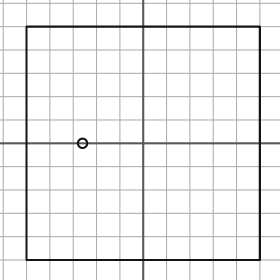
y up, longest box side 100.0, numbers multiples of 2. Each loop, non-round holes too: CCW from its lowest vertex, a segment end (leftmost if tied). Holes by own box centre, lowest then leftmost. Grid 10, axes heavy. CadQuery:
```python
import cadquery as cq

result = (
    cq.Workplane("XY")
    .moveTo(-50.0, -50.0)
    .lineTo(50.0, -50.0)
    .lineTo(50.0, 50.0)
    .lineTo(-50.0, 50.0)
    .close()
    .moveTo(-26.0, 0.0)
    .circle(2.0)
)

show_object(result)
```